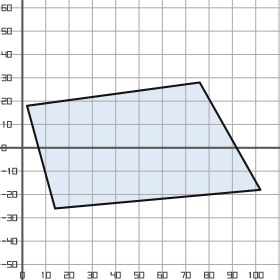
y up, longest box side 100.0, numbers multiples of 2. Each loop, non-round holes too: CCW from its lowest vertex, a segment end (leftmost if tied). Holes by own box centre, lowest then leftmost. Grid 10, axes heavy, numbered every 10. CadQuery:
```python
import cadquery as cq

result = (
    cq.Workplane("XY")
    .moveTo(14.0, -26.0)
    .lineTo(102.0, -18.0)
    .lineTo(76.0, 28.0)
    .lineTo(2.0, 18.0)
    .close()
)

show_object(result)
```